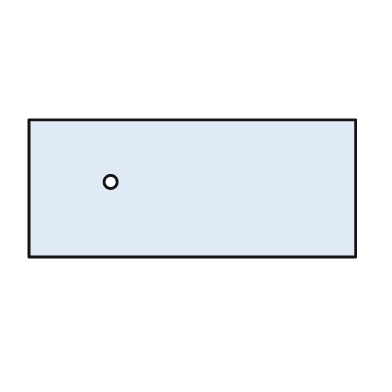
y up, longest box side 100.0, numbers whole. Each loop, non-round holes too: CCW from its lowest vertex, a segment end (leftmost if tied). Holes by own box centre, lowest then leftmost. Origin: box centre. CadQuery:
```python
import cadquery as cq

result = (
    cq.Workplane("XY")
    .moveTo(-50.0, -21.0)
    .lineTo(50.0, -21.0)
    .lineTo(50.0, 21.0)
    .lineTo(-50.0, 21.0)
    .close()
    .moveTo(-25.0, 2.0)
    .circle(2.0)
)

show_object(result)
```